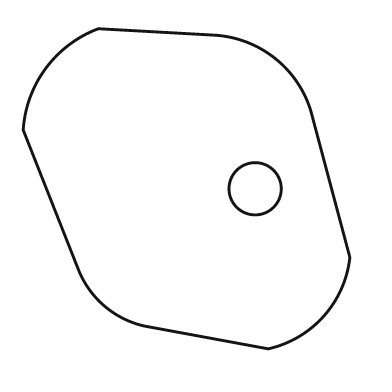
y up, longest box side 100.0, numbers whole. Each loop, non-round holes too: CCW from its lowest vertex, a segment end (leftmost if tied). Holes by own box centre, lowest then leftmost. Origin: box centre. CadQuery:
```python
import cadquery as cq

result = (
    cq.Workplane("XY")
    .moveTo(25.0, -49.0)
    .threePointArc((42.0, -39.0), (50.0, -21.0))
    .lineTo(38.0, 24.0)
    .threePointArc((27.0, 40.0), (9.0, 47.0))
    .lineTo(-27.0, 49.0)
    .threePointArc((-43.0, 37.0), (-50.0, 18.0))
    .lineTo(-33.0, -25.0)
    .threePointArc((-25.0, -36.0), (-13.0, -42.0))
    .close()
    .moveTo(21.0, 0.0)
    .circle(8.0)
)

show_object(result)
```